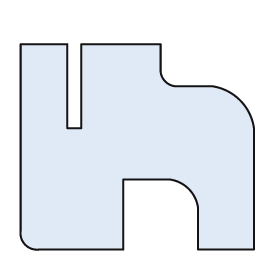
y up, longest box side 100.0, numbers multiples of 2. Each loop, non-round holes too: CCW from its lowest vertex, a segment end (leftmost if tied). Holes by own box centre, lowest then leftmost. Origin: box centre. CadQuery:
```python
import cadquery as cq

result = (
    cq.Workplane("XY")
    .moveTo(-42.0, -44.0)
    .lineTo(-6.0, -44.0)
    .lineTo(-6.0, -14.0)
    .lineTo(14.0, -14.0)
    .threePointArc((22.0, -18.0), (26.0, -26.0))
    .lineTo(26.0, -44.0)
    .lineTo(50.0, -44.0)
    .lineTo(50.0, 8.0)
    .threePointArc((44.0, 20.0), (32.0, 26.0))
    .lineTo(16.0, 26.0)
    .threePointArc((12.0, 28.0), (10.0, 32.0))
    .lineTo(10.0, 44.0)
    .lineTo(-24.0, 44.0)
    .lineTo(-24.0, 8.0)
    .lineTo(-30.0, 8.0)
    .lineTo(-30.0, 44.0)
    .lineTo(-50.0, 44.0)
    .lineTo(-50.0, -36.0)
    .threePointArc((-48.0, -42.0), (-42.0, -44.0))
    .close()
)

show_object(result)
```